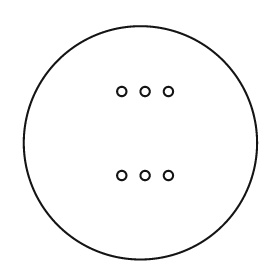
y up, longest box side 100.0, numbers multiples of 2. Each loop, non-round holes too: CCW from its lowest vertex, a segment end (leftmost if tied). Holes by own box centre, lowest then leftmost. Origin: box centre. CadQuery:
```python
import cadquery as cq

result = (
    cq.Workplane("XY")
    .moveTo(0.0, 0.0)
    .circle(50.0)
    .moveTo(-8.0, -14.0)
    .circle(2.0)
    .moveTo(2.0, -14.0)
    .circle(2.0)
    .moveTo(12.0, -14.0)
    .circle(2.0)
    .moveTo(-8.0, 22.0)
    .circle(2.0)
    .moveTo(2.0, 22.0)
    .circle(2.0)
    .moveTo(12.0, 22.0)
    .circle(2.0)
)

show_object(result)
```